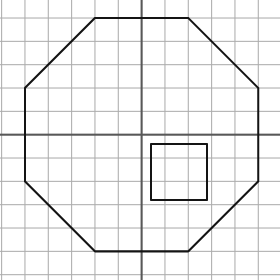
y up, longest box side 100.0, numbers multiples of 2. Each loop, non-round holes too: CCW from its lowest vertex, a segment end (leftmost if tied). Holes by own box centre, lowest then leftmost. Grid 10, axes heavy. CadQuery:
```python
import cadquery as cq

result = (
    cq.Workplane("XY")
    .moveTo(-20.0, -50.0)
    .lineTo(20.0, -50.0)
    .lineTo(50.0, -20.0)
    .lineTo(50.0, 20.0)
    .lineTo(20.0, 50.0)
    .lineTo(-20.0, 50.0)
    .lineTo(-50.0, 20.0)
    .lineTo(-50.0, -20.0)
    .close()
    .moveTo(4.0, -28.0)
    .lineTo(28.0, -28.0)
    .lineTo(28.0, -4.0)
    .lineTo(4.0, -4.0)
    .close()
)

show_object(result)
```